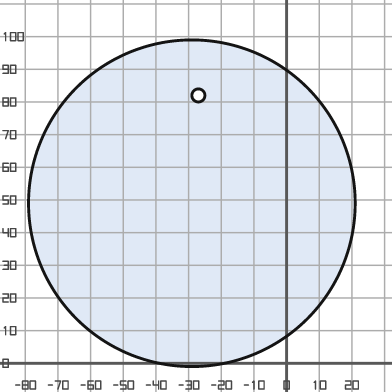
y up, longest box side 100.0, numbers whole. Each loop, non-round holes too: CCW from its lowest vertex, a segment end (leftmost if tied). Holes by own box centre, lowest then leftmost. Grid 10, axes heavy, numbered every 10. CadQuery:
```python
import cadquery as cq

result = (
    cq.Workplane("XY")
    .moveTo(-29.0, 49.0)
    .circle(50.0)
    .moveTo(-27.0, 82.0)
    .circle(2.0)
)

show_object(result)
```